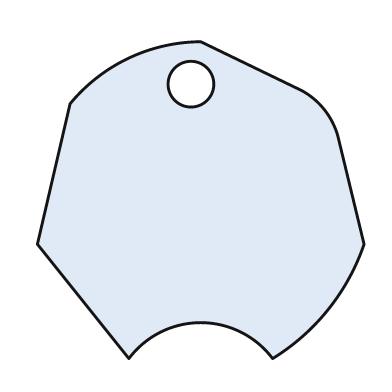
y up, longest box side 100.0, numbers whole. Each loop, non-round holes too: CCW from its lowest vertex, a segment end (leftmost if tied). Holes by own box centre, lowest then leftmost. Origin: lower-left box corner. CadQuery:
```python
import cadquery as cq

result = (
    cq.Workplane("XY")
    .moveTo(28.0, 0.0)
    .threePointArc((50.0, 11.0), (72.0, 0.0))
    .threePointArc((89.0, 15.0), (100.0, 35.0))
    .lineTo(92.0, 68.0)
    .threePointArc((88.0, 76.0), (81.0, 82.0))
    .lineTo(50.0, 97.0)
    .threePointArc((28.0, 92.0), (10.0, 78.0))
    .lineTo(0.0, 35.0)
    .close()
    .moveTo(47.0, 84.0)
    .circle(7.0)
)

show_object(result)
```